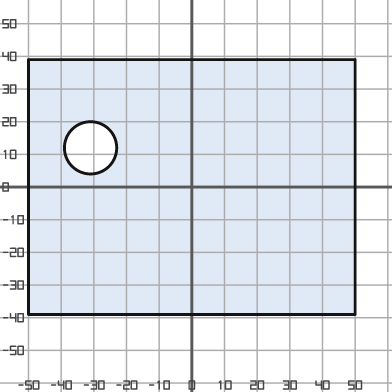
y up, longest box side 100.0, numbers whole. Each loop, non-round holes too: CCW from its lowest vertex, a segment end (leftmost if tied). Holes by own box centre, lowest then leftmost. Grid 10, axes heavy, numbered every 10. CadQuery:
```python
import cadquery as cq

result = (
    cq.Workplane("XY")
    .moveTo(-50.0, -39.0)
    .lineTo(50.0, -39.0)
    .lineTo(50.0, 39.0)
    .lineTo(-50.0, 39.0)
    .close()
    .moveTo(-31.0, 12.0)
    .circle(8.0)
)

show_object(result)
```